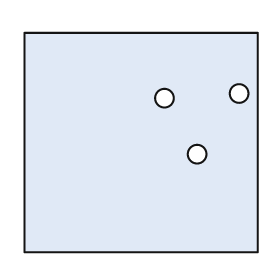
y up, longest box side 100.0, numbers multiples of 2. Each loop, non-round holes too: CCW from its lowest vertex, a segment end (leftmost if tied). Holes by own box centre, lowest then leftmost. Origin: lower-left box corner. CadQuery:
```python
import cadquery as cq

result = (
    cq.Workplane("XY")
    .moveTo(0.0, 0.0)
    .lineTo(100.0, 0.0)
    .lineTo(100.0, 94.0)
    .lineTo(0.0, 94.0)
    .close()
    .moveTo(74.0, 42.0)
    .circle(4.0)
    .moveTo(60.0, 66.0)
    .circle(4.0)
    .moveTo(92.0, 68.0)
    .circle(4.0)
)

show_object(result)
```